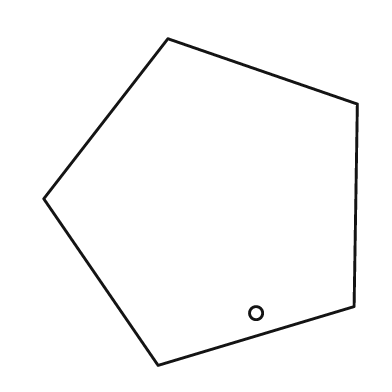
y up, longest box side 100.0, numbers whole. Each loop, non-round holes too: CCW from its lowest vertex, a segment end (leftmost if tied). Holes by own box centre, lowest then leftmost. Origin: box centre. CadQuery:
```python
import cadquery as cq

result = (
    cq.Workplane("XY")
    .moveTo(-13.0, -50.0)
    .lineTo(47.0, -32.0)
    .lineTo(48.0, 30.0)
    .lineTo(-10.0, 50.0)
    .lineTo(-48.0, 1.0)
    .close()
    .moveTo(17.0, -34.0)
    .circle(2.0)
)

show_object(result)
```